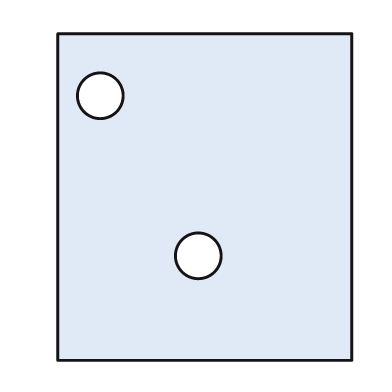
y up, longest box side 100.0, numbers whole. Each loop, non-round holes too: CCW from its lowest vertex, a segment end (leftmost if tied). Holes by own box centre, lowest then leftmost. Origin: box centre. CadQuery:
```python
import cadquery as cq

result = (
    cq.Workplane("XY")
    .moveTo(-45.0, -50.0)
    .lineTo(45.0, -50.0)
    .lineTo(45.0, 50.0)
    .lineTo(-45.0, 50.0)
    .close()
    .moveTo(-2.0, -18.0)
    .circle(7.0)
    .moveTo(-32.0, 31.0)
    .circle(7.0)
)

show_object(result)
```